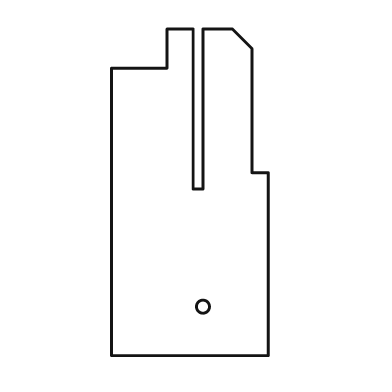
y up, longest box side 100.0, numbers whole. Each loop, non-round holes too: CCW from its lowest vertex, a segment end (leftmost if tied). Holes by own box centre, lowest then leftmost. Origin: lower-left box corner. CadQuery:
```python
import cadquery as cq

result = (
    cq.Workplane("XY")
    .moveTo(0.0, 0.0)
    .lineTo(48.0, 0.0)
    .lineTo(48.0, 56.0)
    .lineTo(43.0, 56.0)
    .lineTo(43.0, 94.0)
    .lineTo(37.0, 100.0)
    .lineTo(28.0, 100.0)
    .lineTo(28.0, 51.0)
    .lineTo(25.0, 51.0)
    .lineTo(25.0, 100.0)
    .lineTo(17.0, 100.0)
    .lineTo(17.0, 88.0)
    .lineTo(0.0, 88.0)
    .close()
    .moveTo(28.0, 15.0)
    .circle(2.0)
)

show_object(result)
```